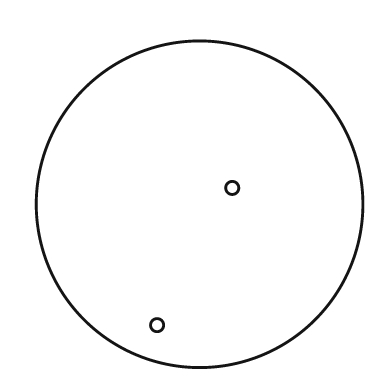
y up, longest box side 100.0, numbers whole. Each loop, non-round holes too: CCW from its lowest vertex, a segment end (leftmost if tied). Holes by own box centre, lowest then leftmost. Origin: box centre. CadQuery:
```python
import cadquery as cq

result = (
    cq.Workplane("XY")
    .moveTo(0.0, 0.0)
    .circle(50.0)
    .moveTo(-13.0, -37.0)
    .circle(2.0)
    .moveTo(10.0, 5.0)
    .circle(2.0)
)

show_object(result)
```